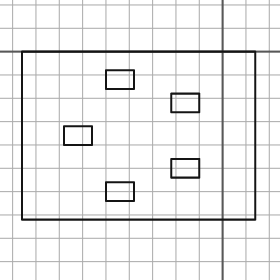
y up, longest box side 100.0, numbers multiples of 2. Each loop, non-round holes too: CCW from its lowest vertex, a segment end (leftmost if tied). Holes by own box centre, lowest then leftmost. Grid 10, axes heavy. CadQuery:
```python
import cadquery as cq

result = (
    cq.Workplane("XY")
    .moveTo(-86.0, -72.0)
    .lineTo(14.0, -72.0)
    .lineTo(14.0, 0.0)
    .lineTo(-86.0, 0.0)
    .close()
    .moveTo(-50.0, -64.0)
    .lineTo(-38.0, -64.0)
    .lineTo(-38.0, -56.0)
    .lineTo(-50.0, -56.0)
    .close()
    .moveTo(-22.0, -54.0)
    .lineTo(-10.0, -54.0)
    .lineTo(-10.0, -46.0)
    .lineTo(-22.0, -46.0)
    .close()
    .moveTo(-68.0, -40.0)
    .lineTo(-56.0, -40.0)
    .lineTo(-56.0, -32.0)
    .lineTo(-68.0, -32.0)
    .close()
    .moveTo(-22.0, -26.0)
    .lineTo(-10.0, -26.0)
    .lineTo(-10.0, -18.0)
    .lineTo(-22.0, -18.0)
    .close()
    .moveTo(-50.0, -16.0)
    .lineTo(-38.0, -16.0)
    .lineTo(-38.0, -8.0)
    .lineTo(-50.0, -8.0)
    .close()
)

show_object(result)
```